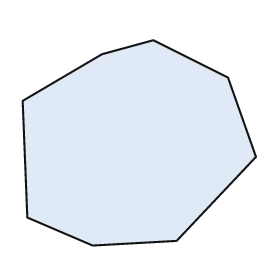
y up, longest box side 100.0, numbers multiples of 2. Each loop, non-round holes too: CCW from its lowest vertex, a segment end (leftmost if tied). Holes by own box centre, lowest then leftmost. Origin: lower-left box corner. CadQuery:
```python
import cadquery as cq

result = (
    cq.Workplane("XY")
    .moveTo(30.0, 0.0)
    .lineTo(66.0, 2.0)
    .lineTo(100.0, 38.0)
    .lineTo(88.0, 72.0)
    .lineTo(56.0, 88.0)
    .lineTo(34.0, 82.0)
    .lineTo(0.0, 62.0)
    .lineTo(2.0, 12.0)
    .close()
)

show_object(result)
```